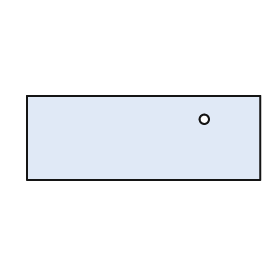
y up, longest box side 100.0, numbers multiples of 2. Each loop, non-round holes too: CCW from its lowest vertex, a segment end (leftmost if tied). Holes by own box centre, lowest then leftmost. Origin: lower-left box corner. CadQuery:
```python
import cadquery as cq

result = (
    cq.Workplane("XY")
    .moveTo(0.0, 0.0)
    .lineTo(100.0, 0.0)
    .lineTo(100.0, 36.0)
    .lineTo(0.0, 36.0)
    .close()
    .moveTo(76.0, 26.0)
    .circle(2.0)
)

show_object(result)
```